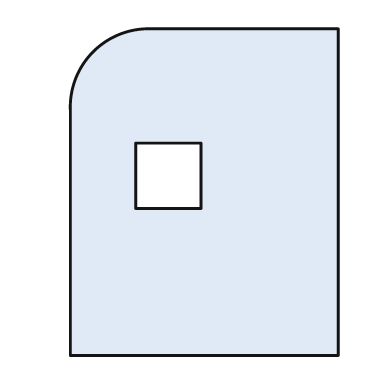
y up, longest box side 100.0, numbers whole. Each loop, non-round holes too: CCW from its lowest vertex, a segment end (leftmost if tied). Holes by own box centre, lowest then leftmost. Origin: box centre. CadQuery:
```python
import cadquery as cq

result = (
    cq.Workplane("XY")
    .moveTo(-41.0, -50.0)
    .lineTo(41.0, -50.0)
    .lineTo(41.0, 50.0)
    .lineTo(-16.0, 50.0)
    .threePointArc((-34.0, 43.0), (-41.0, 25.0))
    .close()
    .moveTo(-21.0, -5.0)
    .lineTo(-1.0, -5.0)
    .lineTo(-1.0, 15.0)
    .lineTo(-21.0, 15.0)
    .close()
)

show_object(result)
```